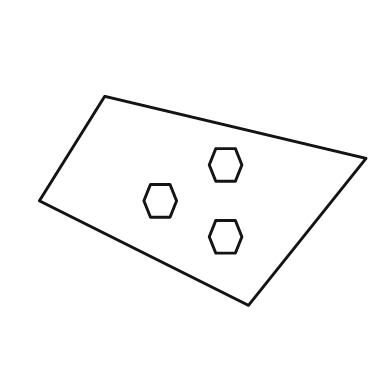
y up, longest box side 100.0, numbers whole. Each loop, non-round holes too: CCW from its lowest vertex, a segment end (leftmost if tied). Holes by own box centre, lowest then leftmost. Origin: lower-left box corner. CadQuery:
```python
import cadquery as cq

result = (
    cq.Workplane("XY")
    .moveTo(64.0, 0.0)
    .lineTo(100.0, 45.0)
    .lineTo(20.0, 64.0)
    .lineTo(0.0, 32.0)
    .close()
    .moveTo(54.0, 16.0)
    .lineTo(60.0, 16.0)
    .lineTo(62.0, 21.0)
    .lineTo(60.0, 26.0)
    .lineTo(54.0, 26.0)
    .lineTo(52.0, 21.0)
    .close()
    .moveTo(34.0, 27.0)
    .lineTo(40.0, 27.0)
    .lineTo(42.0, 32.0)
    .lineTo(40.0, 37.0)
    .lineTo(34.0, 37.0)
    .lineTo(32.0, 32.0)
    .close()
    .moveTo(54.0, 38.0)
    .lineTo(60.0, 38.0)
    .lineTo(62.0, 43.0)
    .lineTo(60.0, 48.0)
    .lineTo(54.0, 48.0)
    .lineTo(52.0, 43.0)
    .close()
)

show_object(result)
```